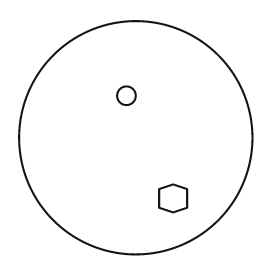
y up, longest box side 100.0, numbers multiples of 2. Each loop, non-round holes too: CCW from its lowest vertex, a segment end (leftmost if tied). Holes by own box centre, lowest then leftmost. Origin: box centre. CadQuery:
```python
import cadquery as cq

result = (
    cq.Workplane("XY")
    .moveTo(0.0, 0.0)
    .circle(50.0)
    .moveTo(16.0, -32.0)
    .lineTo(22.0, -30.0)
    .lineTo(22.0, -22.0)
    .lineTo(16.0, -20.0)
    .lineTo(10.0, -22.0)
    .lineTo(10.0, -30.0)
    .close()
    .moveTo(-4.0, 18.0)
    .circle(4.0)
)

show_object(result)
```